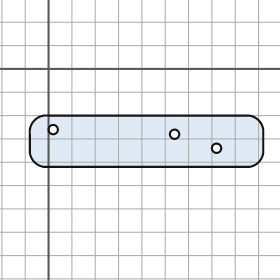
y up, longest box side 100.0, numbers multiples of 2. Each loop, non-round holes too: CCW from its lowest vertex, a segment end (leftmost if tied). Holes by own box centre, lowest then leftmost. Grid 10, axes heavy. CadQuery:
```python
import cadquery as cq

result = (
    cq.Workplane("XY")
    .moveTo(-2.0, -42.0)
    .lineTo(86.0, -42.0)
    .threePointArc((90.0, -40.0), (92.0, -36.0))
    .lineTo(92.0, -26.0)
    .threePointArc((90.0, -22.0), (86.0, -20.0))
    .lineTo(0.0, -20.0)
    .threePointArc((-6.0, -22.0), (-8.0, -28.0))
    .lineTo(-8.0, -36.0)
    .threePointArc((-6.0, -40.0), (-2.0, -42.0))
    .close()
    .moveTo(72.0, -34.0)
    .circle(2.0)
    .moveTo(54.0, -28.0)
    .circle(2.0)
    .moveTo(2.0, -26.0)
    .circle(2.0)
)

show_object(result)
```